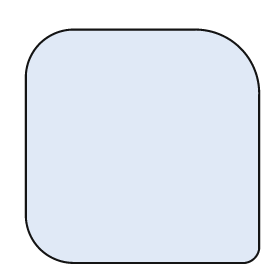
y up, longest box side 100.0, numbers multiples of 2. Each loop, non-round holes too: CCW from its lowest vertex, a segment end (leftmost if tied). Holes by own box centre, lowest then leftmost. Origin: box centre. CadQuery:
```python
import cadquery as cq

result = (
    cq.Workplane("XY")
    .moveTo(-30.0, -50.0)
    .lineTo(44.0, -50.0)
    .threePointArc((48.0, -48.0), (50.0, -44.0))
    .lineTo(50.0, 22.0)
    .threePointArc((42.0, 42.0), (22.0, 50.0))
    .lineTo(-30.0, 50.0)
    .threePointArc((-44.0, 44.0), (-50.0, 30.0))
    .lineTo(-50.0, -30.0)
    .threePointArc((-44.0, -44.0), (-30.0, -50.0))
    .close()
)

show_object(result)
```